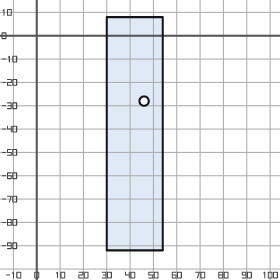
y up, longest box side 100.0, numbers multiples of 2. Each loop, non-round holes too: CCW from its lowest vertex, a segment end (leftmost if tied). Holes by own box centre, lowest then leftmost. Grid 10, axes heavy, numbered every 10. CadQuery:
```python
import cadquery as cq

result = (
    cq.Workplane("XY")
    .moveTo(30.0, -92.0)
    .lineTo(54.0, -92.0)
    .lineTo(54.0, 8.0)
    .lineTo(30.0, 8.0)
    .close()
    .moveTo(46.0, -28.0)
    .circle(2.0)
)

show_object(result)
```